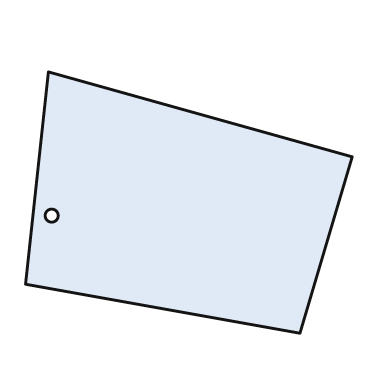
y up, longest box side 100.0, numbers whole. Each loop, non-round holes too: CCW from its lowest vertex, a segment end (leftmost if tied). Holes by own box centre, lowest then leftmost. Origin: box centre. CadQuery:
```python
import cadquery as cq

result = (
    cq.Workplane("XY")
    .moveTo(34.0, -40.0)
    .lineTo(50.0, 14.0)
    .lineTo(-43.0, 40.0)
    .lineTo(-50.0, -25.0)
    .close()
    .moveTo(-42.0, -4.0)
    .circle(2.0)
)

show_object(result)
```